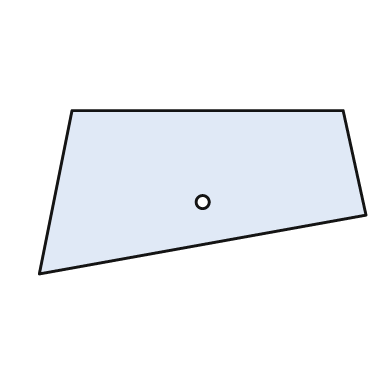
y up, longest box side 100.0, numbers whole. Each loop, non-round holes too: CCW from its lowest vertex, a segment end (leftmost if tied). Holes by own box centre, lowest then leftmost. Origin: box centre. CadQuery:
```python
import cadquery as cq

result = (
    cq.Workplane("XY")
    .moveTo(-50.0, -25.0)
    .lineTo(50.0, -7.0)
    .lineTo(43.0, 25.0)
    .lineTo(-40.0, 25.0)
    .close()
    .moveTo(0.0, -3.0)
    .circle(2.0)
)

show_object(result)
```